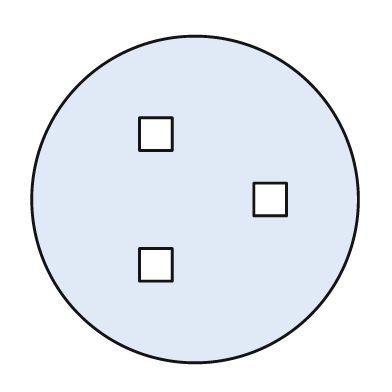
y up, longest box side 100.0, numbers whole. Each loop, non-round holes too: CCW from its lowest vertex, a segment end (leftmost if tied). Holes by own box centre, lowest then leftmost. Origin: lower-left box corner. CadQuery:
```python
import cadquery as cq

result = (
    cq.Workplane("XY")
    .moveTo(50.0, 50.0)
    .circle(50.0)
    .moveTo(33.0, 25.0)
    .lineTo(43.0, 25.0)
    .lineTo(43.0, 35.0)
    .lineTo(33.0, 35.0)
    .close()
    .moveTo(68.0, 45.0)
    .lineTo(78.0, 45.0)
    .lineTo(78.0, 55.0)
    .lineTo(68.0, 55.0)
    .close()
    .moveTo(33.0, 65.0)
    .lineTo(43.0, 65.0)
    .lineTo(43.0, 75.0)
    .lineTo(33.0, 75.0)
    .close()
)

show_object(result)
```